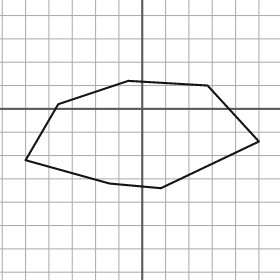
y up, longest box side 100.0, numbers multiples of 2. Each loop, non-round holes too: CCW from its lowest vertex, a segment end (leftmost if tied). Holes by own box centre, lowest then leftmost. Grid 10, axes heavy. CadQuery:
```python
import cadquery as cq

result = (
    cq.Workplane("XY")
    .moveTo(8.0, -34.0)
    .lineTo(50.0, -14.0)
    .lineTo(28.0, 10.0)
    .lineTo(-6.0, 12.0)
    .lineTo(-36.0, 2.0)
    .lineTo(-50.0, -22.0)
    .lineTo(-14.0, -32.0)
    .close()
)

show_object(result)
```